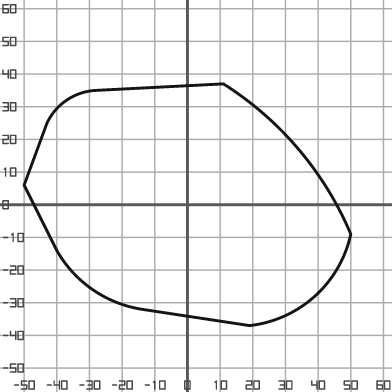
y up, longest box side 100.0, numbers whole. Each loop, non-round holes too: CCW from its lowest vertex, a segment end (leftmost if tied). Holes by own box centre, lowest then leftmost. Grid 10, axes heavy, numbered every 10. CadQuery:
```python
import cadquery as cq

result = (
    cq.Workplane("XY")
    .moveTo(19.0, -37.0)
    .threePointArc((39.0, -28.0), (50.0, -9.0))
    .threePointArc((34.0, 17.0), (11.0, 37.0))
    .lineTo(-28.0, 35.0)
    .threePointArc((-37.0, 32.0), (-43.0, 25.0))
    .lineTo(-50.0, 6.0)
    .lineTo(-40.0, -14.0)
    .threePointArc((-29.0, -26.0), (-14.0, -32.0))
    .close()
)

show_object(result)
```